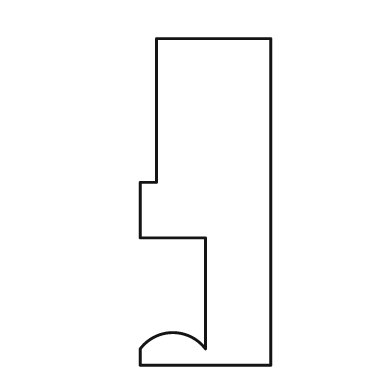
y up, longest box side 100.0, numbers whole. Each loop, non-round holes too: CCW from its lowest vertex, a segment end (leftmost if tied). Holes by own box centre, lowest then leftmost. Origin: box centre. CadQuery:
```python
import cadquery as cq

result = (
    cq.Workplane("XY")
    .moveTo(-20.0, -50.0)
    .lineTo(20.0, -50.0)
    .lineTo(20.0, 50.0)
    .lineTo(-15.0, 50.0)
    .lineTo(-15.0, 6.0)
    .lineTo(-20.0, 6.0)
    .lineTo(-20.0, -11.0)
    .lineTo(0.0, -11.0)
    .lineTo(0.0, -45.0)
    .threePointArc((-10.0, -40.0), (-20.0, -45.0))
    .close()
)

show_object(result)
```